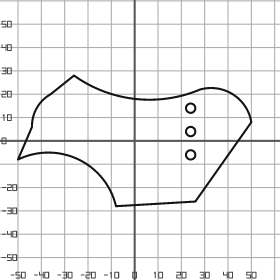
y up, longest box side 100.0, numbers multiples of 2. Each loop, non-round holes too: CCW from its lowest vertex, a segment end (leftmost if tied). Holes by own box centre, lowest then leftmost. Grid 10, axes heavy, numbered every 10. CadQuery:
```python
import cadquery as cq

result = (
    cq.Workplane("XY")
    .moveTo(-8.0, -28.0)
    .lineTo(26.0, -26.0)
    .lineTo(50.0, 8.0)
    .threePointArc((42.0, 20.0), (28.0, 22.0))
    .threePointArc((0.0, 18.0), (-26.0, 28.0))
    .lineTo(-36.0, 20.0)
    .threePointArc((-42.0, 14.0), (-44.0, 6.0))
    .lineTo(-50.0, -8.0)
    .threePointArc((-24.0, -8.0), (-8.0, -28.0))
    .close()
    .moveTo(24.0, -6.0)
    .circle(2.0)
    .moveTo(24.0, 4.0)
    .circle(2.0)
    .moveTo(24.0, 14.0)
    .circle(2.0)
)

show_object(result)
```